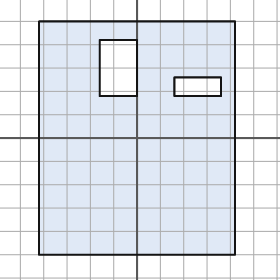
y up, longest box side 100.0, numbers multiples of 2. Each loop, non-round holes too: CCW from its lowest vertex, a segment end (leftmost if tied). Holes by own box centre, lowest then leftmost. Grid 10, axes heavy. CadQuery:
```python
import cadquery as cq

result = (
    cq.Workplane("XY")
    .moveTo(-42.0, -50.0)
    .lineTo(42.0, -50.0)
    .lineTo(42.0, 50.0)
    .lineTo(-42.0, 50.0)
    .close()
    .moveTo(16.0, 18.0)
    .lineTo(36.0, 18.0)
    .lineTo(36.0, 26.0)
    .lineTo(16.0, 26.0)
    .close()
    .moveTo(-16.0, 18.0)
    .lineTo(0.0, 18.0)
    .lineTo(0.0, 42.0)
    .lineTo(-16.0, 42.0)
    .close()
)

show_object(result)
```